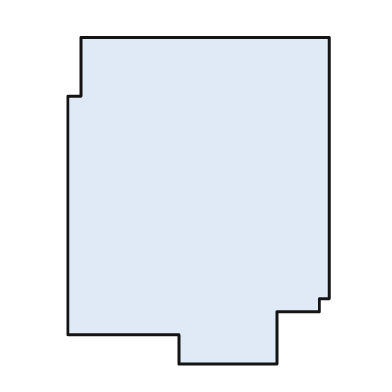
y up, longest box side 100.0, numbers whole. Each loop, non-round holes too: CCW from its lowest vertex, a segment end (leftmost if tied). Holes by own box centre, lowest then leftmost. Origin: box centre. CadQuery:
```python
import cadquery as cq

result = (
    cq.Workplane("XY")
    .moveTo(-6.0, -50.0)
    .lineTo(24.0, -50.0)
    .lineTo(24.0, -34.0)
    .lineTo(37.0, -34.0)
    .lineTo(37.0, -30.0)
    .lineTo(40.0, -30.0)
    .lineTo(40.0, 50.0)
    .lineTo(-36.0, 50.0)
    .lineTo(-36.0, 32.0)
    .lineTo(-40.0, 32.0)
    .lineTo(-40.0, -41.0)
    .lineTo(-6.0, -41.0)
    .close()
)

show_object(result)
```